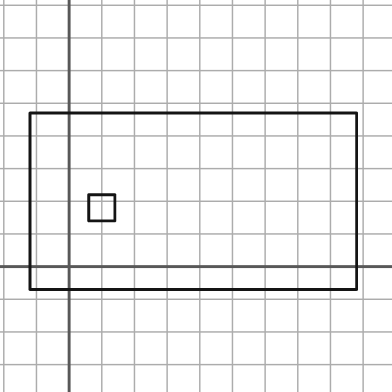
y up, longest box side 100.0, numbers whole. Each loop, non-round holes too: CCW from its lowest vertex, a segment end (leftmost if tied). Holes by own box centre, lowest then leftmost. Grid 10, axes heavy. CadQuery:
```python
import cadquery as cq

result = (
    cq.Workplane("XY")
    .moveTo(-12.0, -7.0)
    .lineTo(88.0, -7.0)
    .lineTo(88.0, 47.0)
    .lineTo(-12.0, 47.0)
    .close()
    .moveTo(6.0, 14.0)
    .lineTo(14.0, 14.0)
    .lineTo(14.0, 22.0)
    .lineTo(6.0, 22.0)
    .close()
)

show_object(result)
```